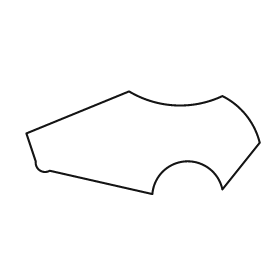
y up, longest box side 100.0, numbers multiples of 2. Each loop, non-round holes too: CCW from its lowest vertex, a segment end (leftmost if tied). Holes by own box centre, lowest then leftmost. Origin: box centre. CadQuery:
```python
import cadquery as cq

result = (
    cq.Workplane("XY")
    .moveTo(4.0, -22.0)
    .threePointArc((18.0, -8.0), (34.0, -20.0))
    .lineTo(50.0, 0.0)
    .threePointArc((44.0, 12.0), (34.0, 20.0))
    .threePointArc((14.0, 16.0), (-6.0, 22.0))
    .lineTo(-50.0, 4.0)
    .lineTo(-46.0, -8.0)
    .threePointArc((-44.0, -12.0), (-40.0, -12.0))
    .close()
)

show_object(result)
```